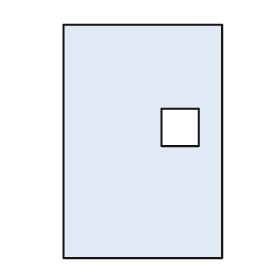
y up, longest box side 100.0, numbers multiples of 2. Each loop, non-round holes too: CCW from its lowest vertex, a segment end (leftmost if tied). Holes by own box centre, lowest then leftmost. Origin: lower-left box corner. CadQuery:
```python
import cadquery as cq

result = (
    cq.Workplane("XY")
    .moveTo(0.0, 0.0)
    .lineTo(68.0, 0.0)
    .lineTo(68.0, 100.0)
    .lineTo(0.0, 100.0)
    .close()
    .moveTo(42.0, 48.0)
    .lineTo(58.0, 48.0)
    .lineTo(58.0, 64.0)
    .lineTo(42.0, 64.0)
    .close()
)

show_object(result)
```